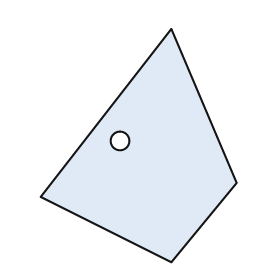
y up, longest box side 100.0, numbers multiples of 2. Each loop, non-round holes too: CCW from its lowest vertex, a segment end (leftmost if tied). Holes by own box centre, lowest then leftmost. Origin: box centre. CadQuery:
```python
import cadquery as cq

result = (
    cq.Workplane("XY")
    .moveTo(14.0, -50.0)
    .lineTo(42.0, -16.0)
    .lineTo(14.0, 50.0)
    .lineTo(-42.0, -22.0)
    .close()
    .moveTo(-8.0, 2.0)
    .circle(4.0)
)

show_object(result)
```